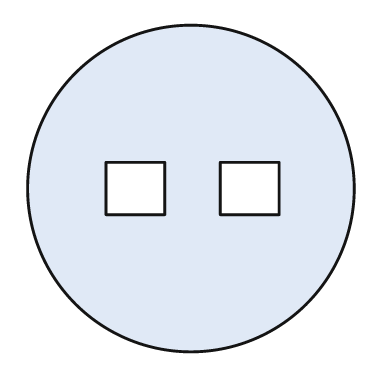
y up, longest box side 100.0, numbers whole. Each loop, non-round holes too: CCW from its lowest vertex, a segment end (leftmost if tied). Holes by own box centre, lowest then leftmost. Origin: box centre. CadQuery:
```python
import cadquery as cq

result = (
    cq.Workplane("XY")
    .moveTo(0.0, 0.0)
    .circle(50.0)
    .moveTo(-26.0, -8.0)
    .lineTo(-8.0, -8.0)
    .lineTo(-8.0, 8.0)
    .lineTo(-26.0, 8.0)
    .close()
    .moveTo(9.0, -8.0)
    .lineTo(27.0, -8.0)
    .lineTo(27.0, 8.0)
    .lineTo(9.0, 8.0)
    .close()
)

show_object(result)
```